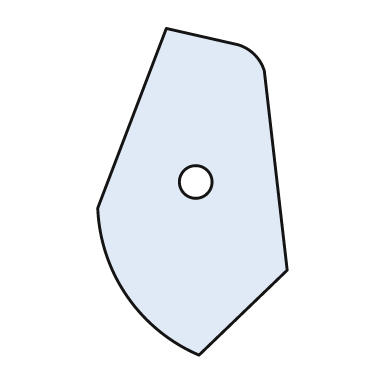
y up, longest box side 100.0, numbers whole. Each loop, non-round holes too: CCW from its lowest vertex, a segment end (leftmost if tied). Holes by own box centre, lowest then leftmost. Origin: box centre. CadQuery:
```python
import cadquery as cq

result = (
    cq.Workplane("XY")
    .moveTo(2.0, -50.0)
    .lineTo(29.0, -24.0)
    .lineTo(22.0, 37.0)
    .threePointArc((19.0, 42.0), (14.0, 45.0))
    .lineTo(-8.0, 50.0)
    .lineTo(-29.0, -5.0)
    .threePointArc((-20.0, -32.0), (2.0, -50.0))
    .close()
    .moveTo(1.0, 3.0)
    .circle(5.0)
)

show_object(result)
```